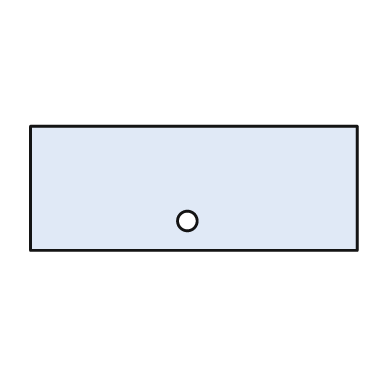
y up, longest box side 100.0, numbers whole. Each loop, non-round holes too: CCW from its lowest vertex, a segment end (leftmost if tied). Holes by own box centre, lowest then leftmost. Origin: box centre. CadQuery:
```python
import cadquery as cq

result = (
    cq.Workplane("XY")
    .moveTo(-50.0, -19.0)
    .lineTo(50.0, -19.0)
    .lineTo(50.0, 19.0)
    .lineTo(-50.0, 19.0)
    .close()
    .moveTo(-2.0, -10.0)
    .circle(3.0)
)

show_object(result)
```